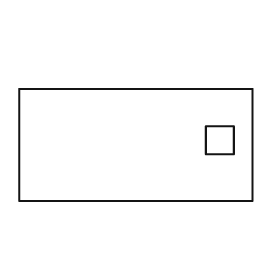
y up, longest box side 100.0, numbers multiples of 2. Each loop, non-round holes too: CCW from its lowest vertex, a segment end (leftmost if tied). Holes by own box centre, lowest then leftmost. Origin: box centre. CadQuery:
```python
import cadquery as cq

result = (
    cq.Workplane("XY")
    .moveTo(-50.0, -24.0)
    .lineTo(50.0, -24.0)
    .lineTo(50.0, 24.0)
    .lineTo(-50.0, 24.0)
    .close()
    .moveTo(30.0, -4.0)
    .lineTo(42.0, -4.0)
    .lineTo(42.0, 8.0)
    .lineTo(30.0, 8.0)
    .close()
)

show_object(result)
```